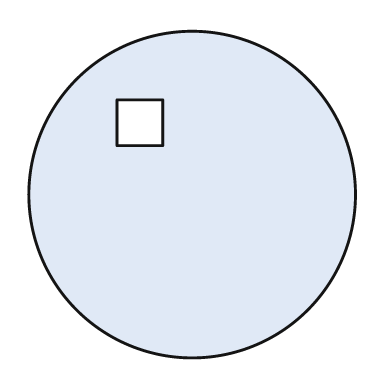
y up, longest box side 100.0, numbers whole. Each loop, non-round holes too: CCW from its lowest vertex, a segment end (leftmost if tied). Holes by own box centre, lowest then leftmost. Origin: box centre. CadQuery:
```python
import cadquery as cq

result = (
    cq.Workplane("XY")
    .moveTo(0.0, 0.0)
    .circle(50.0)
    .moveTo(-23.0, 15.0)
    .lineTo(-9.0, 15.0)
    .lineTo(-9.0, 29.0)
    .lineTo(-23.0, 29.0)
    .close()
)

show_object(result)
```